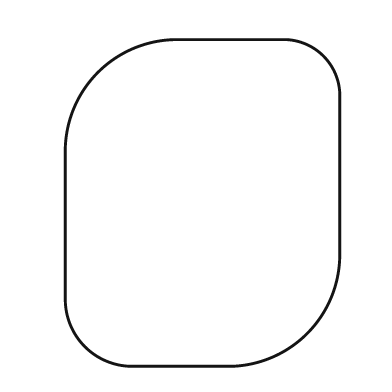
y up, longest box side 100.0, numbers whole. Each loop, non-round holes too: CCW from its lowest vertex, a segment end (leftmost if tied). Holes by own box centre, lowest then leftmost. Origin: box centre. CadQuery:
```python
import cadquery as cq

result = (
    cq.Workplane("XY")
    .moveTo(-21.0, -50.0)
    .lineTo(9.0, -50.0)
    .threePointArc((32.0, -40.0), (42.0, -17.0))
    .lineTo(42.0, 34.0)
    .threePointArc((37.0, 45.0), (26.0, 50.0))
    .lineTo(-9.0, 50.0)
    .threePointArc((-32.0, 40.0), (-42.0, 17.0))
    .lineTo(-42.0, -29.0)
    .threePointArc((-36.0, -44.0), (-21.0, -50.0))
    .close()
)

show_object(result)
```